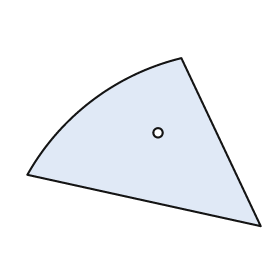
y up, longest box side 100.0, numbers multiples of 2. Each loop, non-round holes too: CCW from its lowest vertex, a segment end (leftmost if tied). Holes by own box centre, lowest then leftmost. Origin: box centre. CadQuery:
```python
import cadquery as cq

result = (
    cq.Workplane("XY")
    .moveTo(50.0, -36.0)
    .lineTo(16.0, 36.0)
    .threePointArc((-22.0, 18.0), (-50.0, -14.0))
    .close()
    .moveTo(6.0, 4.0)
    .circle(2.0)
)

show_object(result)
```